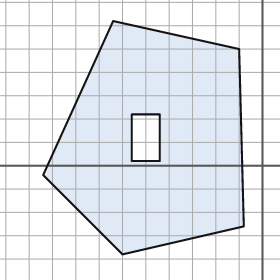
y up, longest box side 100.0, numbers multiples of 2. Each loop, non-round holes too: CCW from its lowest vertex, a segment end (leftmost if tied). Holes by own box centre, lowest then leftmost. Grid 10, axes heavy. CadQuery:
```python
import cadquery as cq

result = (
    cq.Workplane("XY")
    .moveTo(-60.0, -38.0)
    .lineTo(-8.0, -26.0)
    .lineTo(-10.0, 50.0)
    .lineTo(-64.0, 62.0)
    .lineTo(-94.0, -4.0)
    .close()
    .moveTo(-56.0, 2.0)
    .lineTo(-44.0, 2.0)
    .lineTo(-44.0, 22.0)
    .lineTo(-56.0, 22.0)
    .close()
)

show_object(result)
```